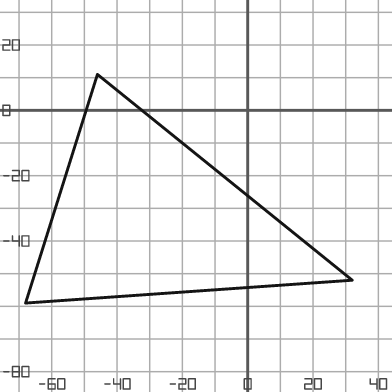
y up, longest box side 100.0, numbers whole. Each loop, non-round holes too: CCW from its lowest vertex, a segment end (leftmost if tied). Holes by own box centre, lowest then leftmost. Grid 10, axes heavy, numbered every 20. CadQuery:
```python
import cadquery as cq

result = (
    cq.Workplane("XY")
    .moveTo(-68.0, -59.0)
    .lineTo(32.0, -52.0)
    .lineTo(-46.0, 11.0)
    .close()
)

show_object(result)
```